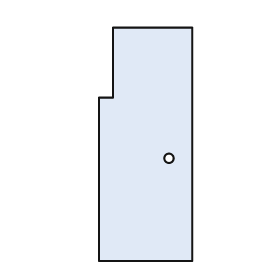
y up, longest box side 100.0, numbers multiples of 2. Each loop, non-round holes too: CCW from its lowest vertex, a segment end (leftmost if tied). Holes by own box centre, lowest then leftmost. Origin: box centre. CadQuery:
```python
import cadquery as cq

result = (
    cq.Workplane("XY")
    .moveTo(-20.0, -50.0)
    .lineTo(20.0, -50.0)
    .lineTo(20.0, 50.0)
    .lineTo(-14.0, 50.0)
    .lineTo(-14.0, 20.0)
    .lineTo(-20.0, 20.0)
    .close()
    .moveTo(10.0, -6.0)
    .circle(2.0)
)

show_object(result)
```